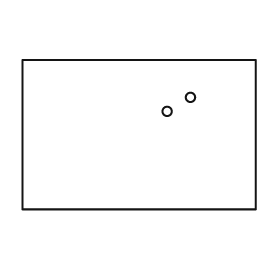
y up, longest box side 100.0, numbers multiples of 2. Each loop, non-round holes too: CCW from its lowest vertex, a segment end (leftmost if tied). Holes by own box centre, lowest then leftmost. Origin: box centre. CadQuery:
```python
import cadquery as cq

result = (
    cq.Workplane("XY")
    .moveTo(-50.0, -32.0)
    .lineTo(50.0, -32.0)
    .lineTo(50.0, 32.0)
    .lineTo(-50.0, 32.0)
    .close()
    .moveTo(12.0, 10.0)
    .circle(2.0)
    .moveTo(22.0, 16.0)
    .circle(2.0)
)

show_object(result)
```